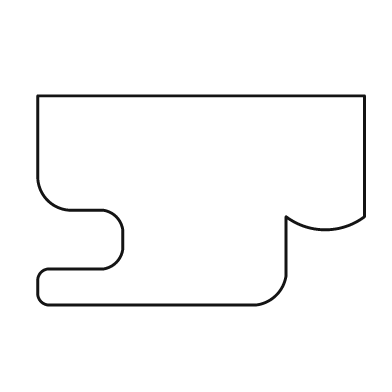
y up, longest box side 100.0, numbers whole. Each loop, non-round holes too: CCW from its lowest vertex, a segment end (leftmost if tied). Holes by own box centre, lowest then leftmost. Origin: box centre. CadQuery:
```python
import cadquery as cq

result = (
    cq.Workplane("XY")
    .moveTo(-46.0, -32.0)
    .lineTo(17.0, -32.0)
    .threePointArc((23.0, -29.0), (26.0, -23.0))
    .lineTo(26.0, -5.0)
    .threePointArc((38.0, -9.0), (50.0, -5.0))
    .lineTo(50.0, 32.0)
    .lineTo(-50.0, 32.0)
    .lineTo(-50.0, 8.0)
    .threePointArc((-47.0, 0.0), (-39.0, -3.0))
    .lineTo(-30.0, -3.0)
    .threePointArc((-26.0, -5.0), (-24.0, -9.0))
    .lineTo(-24.0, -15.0)
    .threePointArc((-26.0, -19.0), (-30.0, -21.0))
    .lineTo(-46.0, -21.0)
    .threePointArc((-49.0, -22.0), (-50.0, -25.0))
    .lineTo(-50.0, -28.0)
    .threePointArc((-49.0, -31.0), (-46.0, -32.0))
    .close()
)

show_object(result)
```